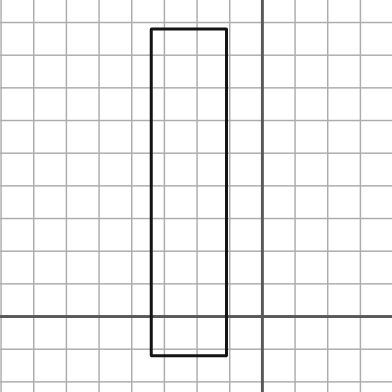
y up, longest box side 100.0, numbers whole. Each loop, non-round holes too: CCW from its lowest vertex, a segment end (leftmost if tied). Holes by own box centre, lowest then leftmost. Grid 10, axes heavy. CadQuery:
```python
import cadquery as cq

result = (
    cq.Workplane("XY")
    .moveTo(-34.0, -12.0)
    .lineTo(-11.0, -12.0)
    .lineTo(-11.0, 88.0)
    .lineTo(-34.0, 88.0)
    .close()
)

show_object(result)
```